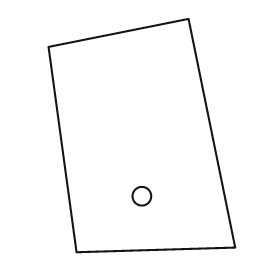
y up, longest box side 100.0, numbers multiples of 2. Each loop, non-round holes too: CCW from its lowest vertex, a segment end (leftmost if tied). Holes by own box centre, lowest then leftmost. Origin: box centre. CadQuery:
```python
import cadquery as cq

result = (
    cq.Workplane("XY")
    .moveTo(-28.0, -50.0)
    .lineTo(40.0, -48.0)
    .lineTo(20.0, 50.0)
    .lineTo(-40.0, 38.0)
    .close()
    .moveTo(0.0, -26.0)
    .circle(4.0)
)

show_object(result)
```